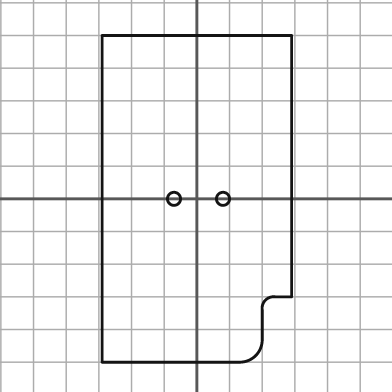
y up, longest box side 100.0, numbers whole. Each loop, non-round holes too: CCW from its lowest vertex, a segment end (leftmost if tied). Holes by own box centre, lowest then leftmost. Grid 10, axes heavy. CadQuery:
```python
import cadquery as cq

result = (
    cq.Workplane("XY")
    .moveTo(-29.0, -50.0)
    .lineTo(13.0, -50.0)
    .threePointArc((18.0, -48.0), (20.0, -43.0))
    .lineTo(20.0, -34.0)
    .threePointArc((21.0, -31.0), (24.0, -30.0))
    .lineTo(29.0, -30.0)
    .lineTo(29.0, 50.0)
    .lineTo(-29.0, 50.0)
    .close()
    .moveTo(-7.0, 0.0)
    .circle(2.0)
    .moveTo(8.0, 0.0)
    .circle(2.0)
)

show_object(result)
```